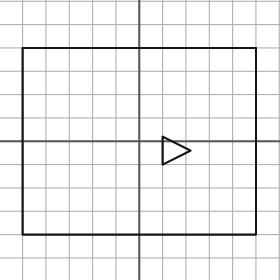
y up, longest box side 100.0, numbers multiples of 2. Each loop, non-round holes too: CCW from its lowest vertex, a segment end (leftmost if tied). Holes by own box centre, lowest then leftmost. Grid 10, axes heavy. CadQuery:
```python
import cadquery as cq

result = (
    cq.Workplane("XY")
    .moveTo(-50.0, -40.0)
    .lineTo(50.0, -40.0)
    .lineTo(50.0, 40.0)
    .lineTo(-50.0, 40.0)
    .close()
    .moveTo(10.0, -10.0)
    .lineTo(22.0, -4.0)
    .lineTo(10.0, 2.0)
    .close()
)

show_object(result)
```